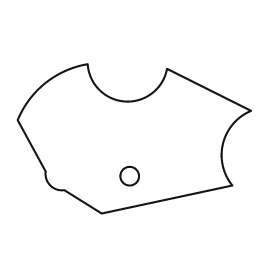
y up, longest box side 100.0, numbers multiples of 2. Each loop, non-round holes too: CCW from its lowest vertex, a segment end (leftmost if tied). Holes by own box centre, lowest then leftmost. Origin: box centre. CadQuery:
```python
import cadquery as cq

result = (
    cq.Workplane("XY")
    .moveTo(-14.0, -32.0)
    .lineTo(42.0, -20.0)
    .threePointArc((38.0, -2.0), (50.0, 12.0))
    .lineTo(14.0, 30.0)
    .threePointArc((-4.0, 16.0), (-20.0, 32.0))
    .threePointArc((-38.0, 24.0), (-50.0, 8.0))
    .lineTo(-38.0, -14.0)
    .threePointArc((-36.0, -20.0), (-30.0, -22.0))
    .close()
    .moveTo(-2.0, -16.0)
    .circle(4.0)
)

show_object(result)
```